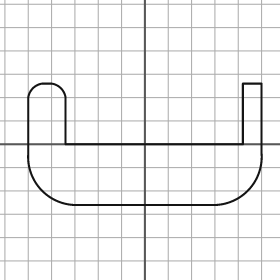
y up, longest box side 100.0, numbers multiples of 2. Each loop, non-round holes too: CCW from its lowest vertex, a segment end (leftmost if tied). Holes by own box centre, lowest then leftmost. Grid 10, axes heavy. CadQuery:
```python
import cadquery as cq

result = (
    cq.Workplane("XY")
    .moveTo(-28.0, -26.0)
    .lineTo(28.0, -26.0)
    .threePointArc((44.0, -20.0), (50.0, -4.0))
    .lineTo(50.0, 26.0)
    .lineTo(42.0, 26.0)
    .lineTo(42.0, 0.0)
    .lineTo(-34.0, 0.0)
    .lineTo(-34.0, 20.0)
    .threePointArc((-36.0, 24.0), (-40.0, 26.0))
    .lineTo(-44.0, 26.0)
    .threePointArc((-48.0, 24.0), (-50.0, 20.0))
    .lineTo(-50.0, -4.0)
    .threePointArc((-44.0, -20.0), (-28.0, -26.0))
    .close()
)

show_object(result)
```